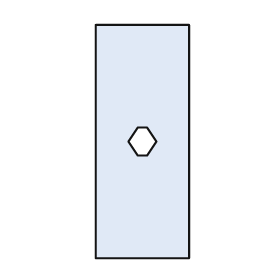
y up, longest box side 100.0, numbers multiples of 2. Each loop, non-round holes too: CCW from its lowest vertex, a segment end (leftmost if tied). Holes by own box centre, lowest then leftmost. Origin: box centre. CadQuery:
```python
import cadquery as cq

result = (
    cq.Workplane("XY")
    .moveTo(-20.0, -50.0)
    .lineTo(20.0, -50.0)
    .lineTo(20.0, 50.0)
    .lineTo(-20.0, 50.0)
    .close()
    .moveTo(-2.0, -6.0)
    .lineTo(2.0, -6.0)
    .lineTo(6.0, 0.0)
    .lineTo(2.0, 6.0)
    .lineTo(-2.0, 6.0)
    .lineTo(-6.0, 0.0)
    .close()
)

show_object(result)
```